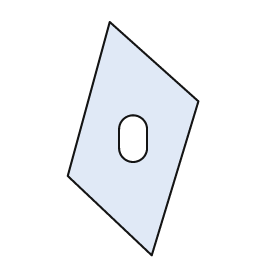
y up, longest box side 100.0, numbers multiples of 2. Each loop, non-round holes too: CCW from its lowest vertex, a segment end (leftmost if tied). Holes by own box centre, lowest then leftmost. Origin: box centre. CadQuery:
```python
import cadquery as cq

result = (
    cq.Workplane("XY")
    .moveTo(8.0, -50.0)
    .lineTo(28.0, 16.0)
    .lineTo(-10.0, 50.0)
    .lineTo(-28.0, -16.0)
    .close()
    .moveTo(-6.0, -4.0)
    .threePointArc((0.0, -10.0), (6.0, -4.0))
    .lineTo(6.0, 4.0)
    .threePointArc((0.0, 10.0), (-6.0, 4.0))
    .close()
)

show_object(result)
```